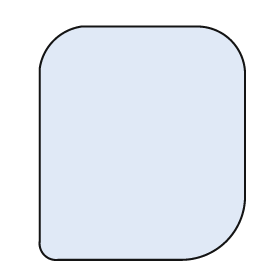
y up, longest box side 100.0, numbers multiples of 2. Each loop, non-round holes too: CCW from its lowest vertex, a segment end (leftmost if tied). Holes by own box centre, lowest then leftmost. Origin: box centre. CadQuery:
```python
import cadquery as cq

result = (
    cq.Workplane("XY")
    .moveTo(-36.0, -50.0)
    .lineTo(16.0, -50.0)
    .threePointArc((36.0, -42.0), (44.0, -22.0))
    .lineTo(44.0, 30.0)
    .threePointArc((38.0, 44.0), (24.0, 50.0))
    .lineTo(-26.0, 50.0)
    .threePointArc((-38.0, 44.0), (-44.0, 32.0))
    .lineTo(-44.0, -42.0)
    .threePointArc((-42.0, -48.0), (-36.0, -50.0))
    .close()
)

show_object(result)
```